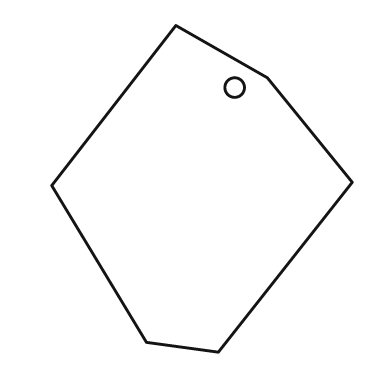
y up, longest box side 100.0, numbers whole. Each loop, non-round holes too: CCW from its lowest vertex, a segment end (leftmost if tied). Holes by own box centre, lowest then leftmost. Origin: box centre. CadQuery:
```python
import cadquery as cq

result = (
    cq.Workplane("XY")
    .moveTo(5.0, -50.0)
    .lineTo(46.0, 2.0)
    .lineTo(20.0, 34.0)
    .lineTo(-8.0, 50.0)
    .lineTo(-46.0, 1.0)
    .lineTo(-17.0, -47.0)
    .close()
    .moveTo(10.0, 31.0)
    .circle(3.0)
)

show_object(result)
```